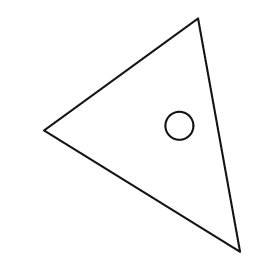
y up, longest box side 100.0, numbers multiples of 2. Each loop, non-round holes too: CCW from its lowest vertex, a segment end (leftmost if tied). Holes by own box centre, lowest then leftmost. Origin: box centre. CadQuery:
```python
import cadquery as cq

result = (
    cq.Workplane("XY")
    .moveTo(42.0, -50.0)
    .lineTo(24.0, 50.0)
    .lineTo(-42.0, 2.0)
    .close()
    .moveTo(16.0, 4.0)
    .circle(6.0)
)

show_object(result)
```